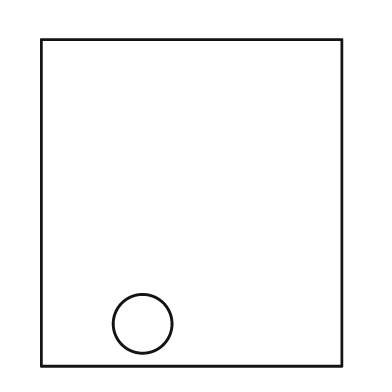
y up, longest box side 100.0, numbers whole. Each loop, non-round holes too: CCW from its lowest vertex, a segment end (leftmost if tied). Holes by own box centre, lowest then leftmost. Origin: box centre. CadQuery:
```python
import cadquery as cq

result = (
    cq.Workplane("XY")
    .moveTo(-46.0, -50.0)
    .lineTo(46.0, -50.0)
    .lineTo(46.0, 50.0)
    .lineTo(-46.0, 50.0)
    .close()
    .moveTo(-15.0, -37.0)
    .circle(9.0)
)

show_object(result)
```